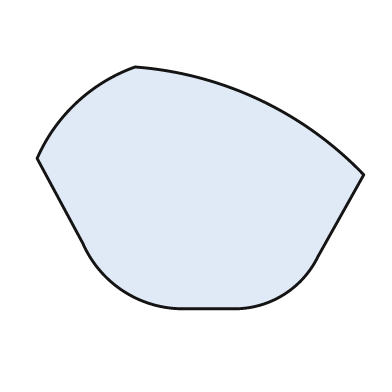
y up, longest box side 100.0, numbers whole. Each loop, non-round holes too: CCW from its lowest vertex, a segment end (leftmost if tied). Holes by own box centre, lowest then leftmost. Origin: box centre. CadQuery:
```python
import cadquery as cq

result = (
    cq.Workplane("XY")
    .moveTo(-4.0, -37.0)
    .lineTo(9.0, -37.0)
    .threePointArc((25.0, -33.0), (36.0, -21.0))
    .lineTo(50.0, 4.0)
    .threePointArc((18.0, 27.0), (-20.0, 37.0))
    .threePointArc((-38.0, 26.0), (-50.0, 9.0))
    .lineTo(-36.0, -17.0)
    .threePointArc((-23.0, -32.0), (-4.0, -37.0))
    .close()
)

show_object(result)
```